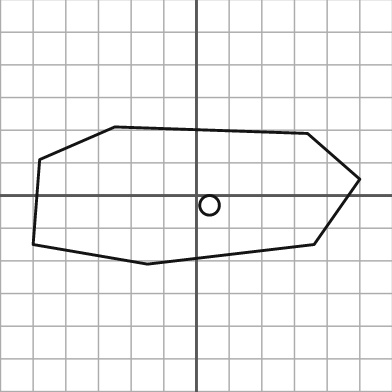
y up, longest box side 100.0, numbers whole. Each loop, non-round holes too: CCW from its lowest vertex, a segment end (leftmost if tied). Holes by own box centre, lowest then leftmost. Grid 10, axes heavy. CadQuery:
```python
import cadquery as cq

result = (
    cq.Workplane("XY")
    .moveTo(-15.0, -21.0)
    .lineTo(36.0, -15.0)
    .lineTo(50.0, 5.0)
    .lineTo(34.0, 19.0)
    .lineTo(-25.0, 21.0)
    .lineTo(-48.0, 11.0)
    .lineTo(-50.0, -15.0)
    .close()
    .moveTo(4.0, -3.0)
    .circle(3.0)
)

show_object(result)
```